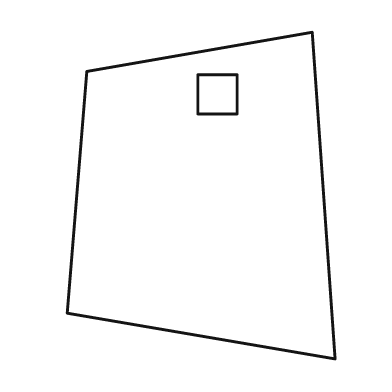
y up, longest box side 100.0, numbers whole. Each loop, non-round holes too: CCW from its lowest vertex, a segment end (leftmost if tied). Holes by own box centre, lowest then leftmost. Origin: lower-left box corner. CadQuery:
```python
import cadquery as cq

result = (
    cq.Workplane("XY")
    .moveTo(82.0, 0.0)
    .lineTo(75.0, 100.0)
    .lineTo(6.0, 88.0)
    .lineTo(0.0, 14.0)
    .close()
    .moveTo(40.0, 75.0)
    .lineTo(52.0, 75.0)
    .lineTo(52.0, 87.0)
    .lineTo(40.0, 87.0)
    .close()
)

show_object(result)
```